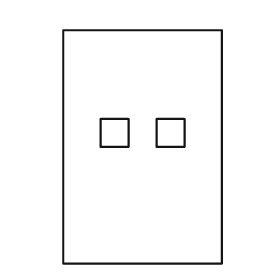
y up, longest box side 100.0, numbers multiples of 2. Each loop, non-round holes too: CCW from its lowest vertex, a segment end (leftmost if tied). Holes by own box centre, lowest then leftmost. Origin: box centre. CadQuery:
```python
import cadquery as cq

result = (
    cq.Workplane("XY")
    .moveTo(-34.0, -50.0)
    .lineTo(34.0, -50.0)
    .lineTo(34.0, 50.0)
    .lineTo(-34.0, 50.0)
    .close()
    .moveTo(-18.0, 0.0)
    .lineTo(-6.0, 0.0)
    .lineTo(-6.0, 12.0)
    .lineTo(-18.0, 12.0)
    .close()
    .moveTo(6.0, 0.0)
    .lineTo(18.0, 0.0)
    .lineTo(18.0, 12.0)
    .lineTo(6.0, 12.0)
    .close()
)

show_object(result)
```